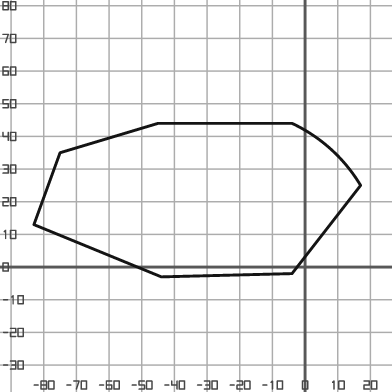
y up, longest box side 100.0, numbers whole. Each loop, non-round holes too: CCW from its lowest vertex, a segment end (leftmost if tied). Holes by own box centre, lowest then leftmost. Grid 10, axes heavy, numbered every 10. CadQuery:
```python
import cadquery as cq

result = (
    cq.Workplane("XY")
    .moveTo(-44.0, -3.0)
    .lineTo(-4.0, -2.0)
    .lineTo(17.0, 25.0)
    .threePointArc((8.0, 36.0), (-4.0, 44.0))
    .lineTo(-45.0, 44.0)
    .lineTo(-75.0, 35.0)
    .lineTo(-83.0, 13.0)
    .close()
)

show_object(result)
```